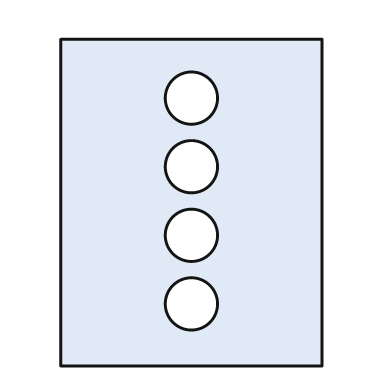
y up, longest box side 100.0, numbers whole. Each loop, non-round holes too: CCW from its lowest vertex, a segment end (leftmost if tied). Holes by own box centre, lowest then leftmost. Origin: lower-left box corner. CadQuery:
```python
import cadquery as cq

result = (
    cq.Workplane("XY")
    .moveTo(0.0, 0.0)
    .lineTo(80.0, 0.0)
    .lineTo(80.0, 100.0)
    .lineTo(0.0, 100.0)
    .close()
    .moveTo(40.0, 19.0)
    .circle(8.0)
    .moveTo(40.0, 40.0)
    .circle(8.0)
    .moveTo(40.0, 61.0)
    .circle(8.0)
    .moveTo(40.0, 82.0)
    .circle(8.0)
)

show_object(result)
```